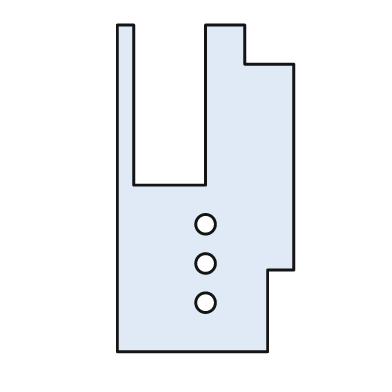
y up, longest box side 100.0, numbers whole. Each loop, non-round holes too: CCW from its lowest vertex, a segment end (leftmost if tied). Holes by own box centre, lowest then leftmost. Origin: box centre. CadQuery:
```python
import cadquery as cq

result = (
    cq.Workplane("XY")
    .moveTo(-27.0, -50.0)
    .lineTo(19.0, -50.0)
    .lineTo(19.0, -25.0)
    .lineTo(27.0, -25.0)
    .lineTo(27.0, 38.0)
    .lineTo(12.0, 38.0)
    .lineTo(12.0, 50.0)
    .lineTo(0.0, 50.0)
    .lineTo(0.0, 1.0)
    .lineTo(-22.0, 1.0)
    .lineTo(-22.0, 50.0)
    .lineTo(-27.0, 50.0)
    .close()
    .moveTo(0.0, -35.0)
    .circle(3.0)
    .moveTo(0.0, -23.0)
    .circle(3.0)
    .moveTo(0.0, -11.0)
    .circle(3.0)
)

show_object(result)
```